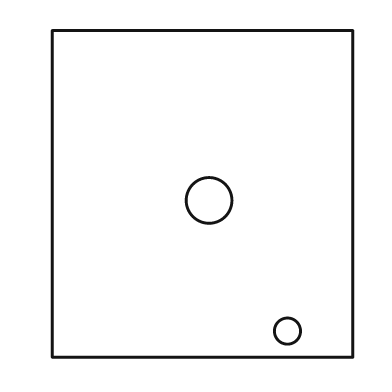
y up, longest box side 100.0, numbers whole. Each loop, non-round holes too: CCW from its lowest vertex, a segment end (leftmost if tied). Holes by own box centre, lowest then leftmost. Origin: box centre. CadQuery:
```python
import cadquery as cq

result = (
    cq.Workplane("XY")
    .moveTo(-46.0, -50.0)
    .lineTo(46.0, -50.0)
    .lineTo(46.0, 50.0)
    .lineTo(-46.0, 50.0)
    .close()
    .moveTo(26.0, -42.0)
    .circle(4.0)
    .moveTo(2.0, -2.0)
    .circle(7.0)
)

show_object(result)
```